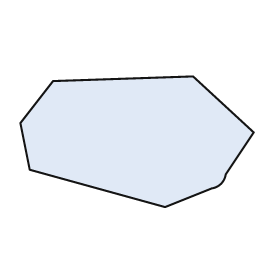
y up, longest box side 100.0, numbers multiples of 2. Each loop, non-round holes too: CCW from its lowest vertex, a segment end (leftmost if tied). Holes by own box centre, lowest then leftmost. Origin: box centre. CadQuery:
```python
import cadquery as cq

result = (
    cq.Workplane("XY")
    .moveTo(12.0, -28.0)
    .lineTo(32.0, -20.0)
    .threePointArc((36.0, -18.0), (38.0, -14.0))
    .lineTo(50.0, 4.0)
    .lineTo(24.0, 28.0)
    .lineTo(-36.0, 26.0)
    .lineTo(-50.0, 8.0)
    .lineTo(-46.0, -12.0)
    .close()
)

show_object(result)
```